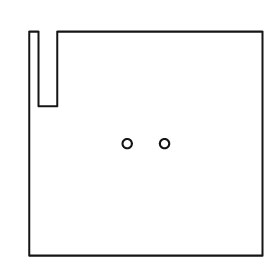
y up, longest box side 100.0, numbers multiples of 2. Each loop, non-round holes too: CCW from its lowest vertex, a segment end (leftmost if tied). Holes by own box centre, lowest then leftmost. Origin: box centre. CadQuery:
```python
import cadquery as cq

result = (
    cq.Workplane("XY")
    .moveTo(-50.0, -48.0)
    .lineTo(50.0, -48.0)
    .lineTo(50.0, 48.0)
    .lineTo(-38.0, 48.0)
    .lineTo(-38.0, 16.0)
    .lineTo(-46.0, 16.0)
    .lineTo(-46.0, 48.0)
    .lineTo(-50.0, 48.0)
    .close()
    .moveTo(-8.0, 0.0)
    .circle(2.0)
    .moveTo(8.0, 0.0)
    .circle(2.0)
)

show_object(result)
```